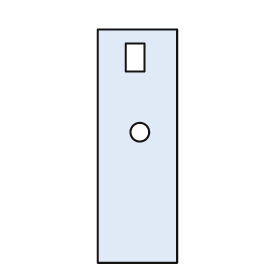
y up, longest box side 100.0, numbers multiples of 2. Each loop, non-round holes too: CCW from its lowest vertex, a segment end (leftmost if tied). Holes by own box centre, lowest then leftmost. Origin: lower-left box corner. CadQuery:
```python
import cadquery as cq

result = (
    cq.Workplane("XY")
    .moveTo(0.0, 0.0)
    .lineTo(34.0, 0.0)
    .lineTo(34.0, 100.0)
    .lineTo(0.0, 100.0)
    .close()
    .moveTo(18.0, 56.0)
    .circle(4.0)
    .moveTo(12.0, 82.0)
    .lineTo(20.0, 82.0)
    .lineTo(20.0, 94.0)
    .lineTo(12.0, 94.0)
    .close()
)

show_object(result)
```